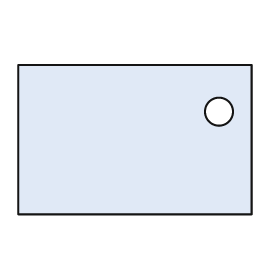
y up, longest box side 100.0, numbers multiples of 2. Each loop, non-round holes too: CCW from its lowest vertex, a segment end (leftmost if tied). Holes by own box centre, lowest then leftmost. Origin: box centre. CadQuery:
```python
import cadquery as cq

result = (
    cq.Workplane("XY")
    .moveTo(-50.0, -32.0)
    .lineTo(50.0, -32.0)
    .lineTo(50.0, 32.0)
    .lineTo(-50.0, 32.0)
    .close()
    .moveTo(36.0, 12.0)
    .circle(6.0)
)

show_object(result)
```